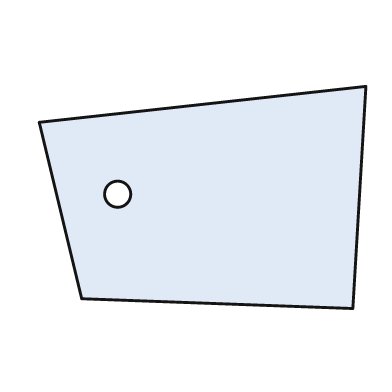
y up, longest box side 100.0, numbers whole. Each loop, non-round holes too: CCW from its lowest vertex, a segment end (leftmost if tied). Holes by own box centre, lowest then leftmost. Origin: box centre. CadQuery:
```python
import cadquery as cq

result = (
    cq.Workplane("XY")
    .moveTo(46.0, -34.0)
    .lineTo(50.0, 34.0)
    .lineTo(-50.0, 23.0)
    .lineTo(-37.0, -31.0)
    .close()
    .moveTo(-26.0, 1.0)
    .circle(4.0)
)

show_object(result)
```